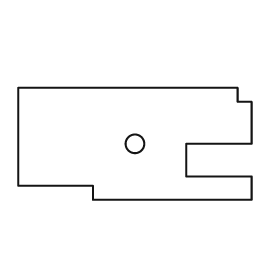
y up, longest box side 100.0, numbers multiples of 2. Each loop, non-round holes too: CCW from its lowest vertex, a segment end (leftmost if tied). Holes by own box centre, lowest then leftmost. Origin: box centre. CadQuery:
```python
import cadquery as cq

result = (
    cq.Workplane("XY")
    .moveTo(-18.0, -24.0)
    .lineTo(50.0, -24.0)
    .lineTo(50.0, -14.0)
    .lineTo(22.0, -14.0)
    .lineTo(22.0, 0.0)
    .lineTo(50.0, 0.0)
    .lineTo(50.0, 18.0)
    .lineTo(44.0, 18.0)
    .lineTo(44.0, 24.0)
    .lineTo(-50.0, 24.0)
    .lineTo(-50.0, -18.0)
    .lineTo(-18.0, -18.0)
    .close()
    .moveTo(0.0, 0.0)
    .circle(4.0)
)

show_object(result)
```